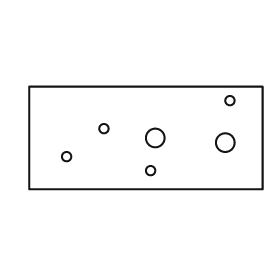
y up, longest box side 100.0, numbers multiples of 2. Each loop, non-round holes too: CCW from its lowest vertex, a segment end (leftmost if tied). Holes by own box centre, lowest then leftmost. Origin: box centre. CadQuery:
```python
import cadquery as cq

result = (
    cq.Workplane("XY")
    .moveTo(-50.0, -22.0)
    .lineTo(50.0, -22.0)
    .lineTo(50.0, 22.0)
    .lineTo(-50.0, 22.0)
    .close()
    .moveTo(2.0, -14.0)
    .circle(2.0)
    .moveTo(-34.0, -8.0)
    .circle(2.0)
    .moveTo(34.0, -2.0)
    .circle(4.0)
    .moveTo(4.0, 0.0)
    .circle(4.0)
    .moveTo(-18.0, 4.0)
    .circle(2.0)
    .moveTo(36.0, 16.0)
    .circle(2.0)
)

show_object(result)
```